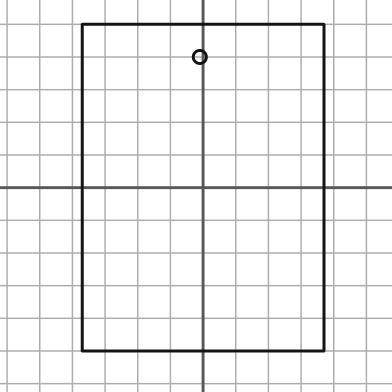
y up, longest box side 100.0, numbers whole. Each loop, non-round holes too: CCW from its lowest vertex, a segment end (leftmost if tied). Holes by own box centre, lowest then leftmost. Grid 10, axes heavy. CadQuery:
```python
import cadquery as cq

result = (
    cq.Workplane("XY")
    .moveTo(-37.0, -50.0)
    .lineTo(37.0, -50.0)
    .lineTo(37.0, 50.0)
    .lineTo(-37.0, 50.0)
    .close()
    .moveTo(-1.0, 40.0)
    .circle(2.0)
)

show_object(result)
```